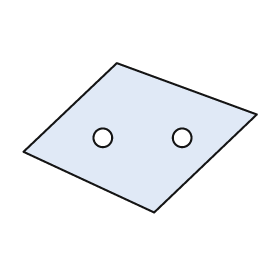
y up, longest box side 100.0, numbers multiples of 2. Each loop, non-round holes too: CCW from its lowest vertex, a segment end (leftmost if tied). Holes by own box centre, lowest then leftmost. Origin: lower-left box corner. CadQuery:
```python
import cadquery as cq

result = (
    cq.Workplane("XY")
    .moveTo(56.0, 0.0)
    .lineTo(100.0, 42.0)
    .lineTo(40.0, 64.0)
    .lineTo(0.0, 26.0)
    .close()
    .moveTo(34.0, 32.0)
    .circle(4.0)
    .moveTo(68.0, 32.0)
    .circle(4.0)
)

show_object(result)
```